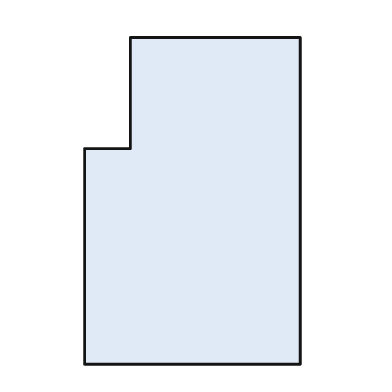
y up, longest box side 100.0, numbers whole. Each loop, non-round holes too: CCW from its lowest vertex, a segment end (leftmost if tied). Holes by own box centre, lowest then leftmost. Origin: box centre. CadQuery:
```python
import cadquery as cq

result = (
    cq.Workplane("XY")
    .moveTo(-33.0, -50.0)
    .lineTo(33.0, -50.0)
    .lineTo(33.0, 50.0)
    .lineTo(-19.0, 50.0)
    .lineTo(-19.0, 16.0)
    .lineTo(-33.0, 16.0)
    .close()
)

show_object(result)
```